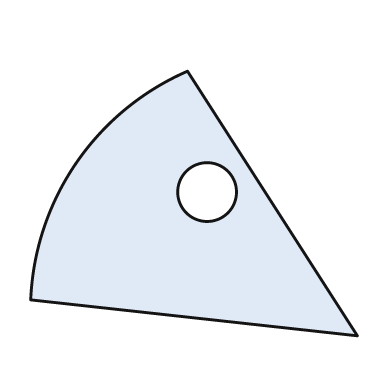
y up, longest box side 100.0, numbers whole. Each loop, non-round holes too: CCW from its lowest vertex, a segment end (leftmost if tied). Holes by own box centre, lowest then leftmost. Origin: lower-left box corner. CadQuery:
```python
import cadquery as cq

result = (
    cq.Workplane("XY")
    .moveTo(100.0, 0.0)
    .lineTo(48.0, 81.0)
    .threePointArc((14.0, 53.0), (0.0, 11.0))
    .close()
    .moveTo(54.0, 44.0)
    .circle(9.0)
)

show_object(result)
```